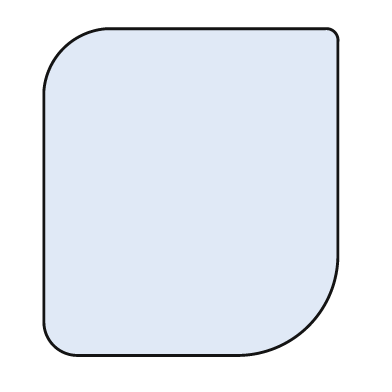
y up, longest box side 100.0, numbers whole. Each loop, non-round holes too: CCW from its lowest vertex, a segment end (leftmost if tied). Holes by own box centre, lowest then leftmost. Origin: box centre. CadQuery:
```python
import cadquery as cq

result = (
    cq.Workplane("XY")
    .moveTo(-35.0, -50.0)
    .lineTo(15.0, -50.0)
    .threePointArc((36.0, -41.0), (45.0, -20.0))
    .lineTo(45.0, 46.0)
    .threePointArc((44.0, 49.0), (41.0, 50.0))
    .lineTo(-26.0, 50.0)
    .threePointArc((-39.0, 44.0), (-45.0, 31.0))
    .lineTo(-45.0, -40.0)
    .threePointArc((-42.0, -47.0), (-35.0, -50.0))
    .close()
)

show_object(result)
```